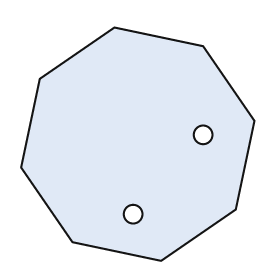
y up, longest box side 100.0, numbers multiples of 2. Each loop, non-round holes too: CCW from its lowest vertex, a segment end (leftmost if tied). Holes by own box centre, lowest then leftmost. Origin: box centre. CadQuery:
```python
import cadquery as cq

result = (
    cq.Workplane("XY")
    .moveTo(10.0, -50.0)
    .lineTo(42.0, -28.0)
    .lineTo(50.0, 10.0)
    .lineTo(28.0, 42.0)
    .lineTo(-10.0, 50.0)
    .lineTo(-42.0, 28.0)
    .lineTo(-50.0, -10.0)
    .lineTo(-28.0, -42.0)
    .close()
    .moveTo(-2.0, -30.0)
    .circle(4.0)
    .moveTo(28.0, 4.0)
    .circle(4.0)
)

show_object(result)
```